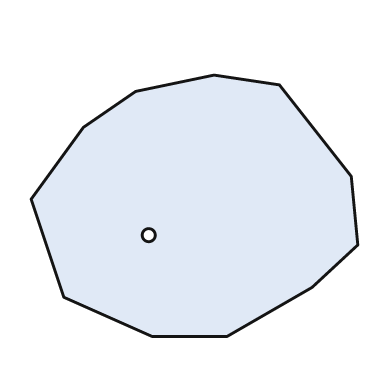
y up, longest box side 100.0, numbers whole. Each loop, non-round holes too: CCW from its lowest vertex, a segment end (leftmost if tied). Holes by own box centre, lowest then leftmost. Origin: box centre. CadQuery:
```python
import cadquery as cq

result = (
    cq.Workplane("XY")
    .moveTo(-13.0, -40.0)
    .lineTo(10.0, -40.0)
    .lineTo(36.0, -25.0)
    .lineTo(50.0, -12.0)
    .lineTo(48.0, 9.0)
    .lineTo(26.0, 37.0)
    .lineTo(6.0, 40.0)
    .lineTo(-18.0, 35.0)
    .lineTo(-34.0, 24.0)
    .lineTo(-50.0, 2.0)
    .lineTo(-40.0, -28.0)
    .close()
    .moveTo(-14.0, -9.0)
    .circle(2.0)
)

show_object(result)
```